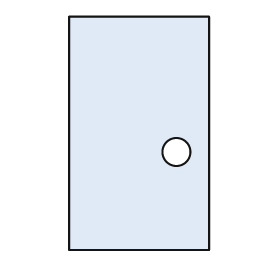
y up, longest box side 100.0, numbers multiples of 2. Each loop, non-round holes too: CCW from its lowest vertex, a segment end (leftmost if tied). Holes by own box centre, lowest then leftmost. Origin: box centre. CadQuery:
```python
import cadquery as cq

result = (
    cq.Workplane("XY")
    .moveTo(-30.0, -50.0)
    .lineTo(30.0, -50.0)
    .lineTo(30.0, 50.0)
    .lineTo(-30.0, 50.0)
    .close()
    .moveTo(16.0, -8.0)
    .circle(6.0)
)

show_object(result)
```